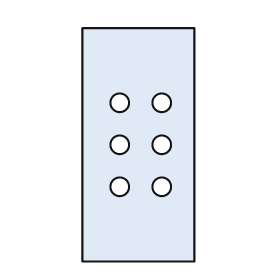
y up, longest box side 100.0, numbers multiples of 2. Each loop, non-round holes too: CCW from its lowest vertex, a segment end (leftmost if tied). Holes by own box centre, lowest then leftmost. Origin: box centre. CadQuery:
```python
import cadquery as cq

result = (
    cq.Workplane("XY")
    .moveTo(-24.0, -50.0)
    .lineTo(24.0, -50.0)
    .lineTo(24.0, 50.0)
    .lineTo(-24.0, 50.0)
    .close()
    .moveTo(-8.0, -18.0)
    .circle(4.0)
    .moveTo(10.0, -18.0)
    .circle(4.0)
    .moveTo(-8.0, 0.0)
    .circle(4.0)
    .moveTo(10.0, 0.0)
    .circle(4.0)
    .moveTo(-8.0, 18.0)
    .circle(4.0)
    .moveTo(10.0, 18.0)
    .circle(4.0)
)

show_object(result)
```